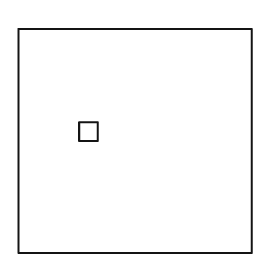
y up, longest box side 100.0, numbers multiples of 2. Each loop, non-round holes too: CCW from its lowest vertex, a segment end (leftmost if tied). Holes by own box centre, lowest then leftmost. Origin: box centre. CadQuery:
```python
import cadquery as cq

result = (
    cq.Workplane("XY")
    .moveTo(-50.0, -48.0)
    .lineTo(50.0, -48.0)
    .lineTo(50.0, 48.0)
    .lineTo(-50.0, 48.0)
    .close()
    .moveTo(-24.0, 0.0)
    .lineTo(-16.0, 0.0)
    .lineTo(-16.0, 8.0)
    .lineTo(-24.0, 8.0)
    .close()
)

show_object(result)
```